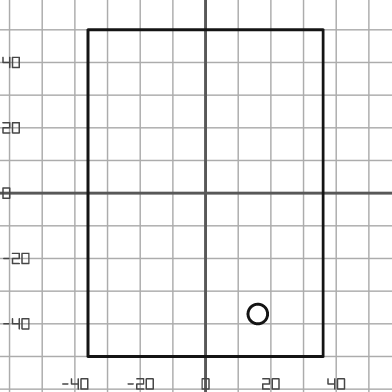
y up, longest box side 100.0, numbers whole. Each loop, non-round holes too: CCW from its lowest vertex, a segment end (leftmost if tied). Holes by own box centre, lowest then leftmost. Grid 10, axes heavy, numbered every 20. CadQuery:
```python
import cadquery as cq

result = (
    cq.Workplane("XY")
    .moveTo(-36.0, -50.0)
    .lineTo(36.0, -50.0)
    .lineTo(36.0, 50.0)
    .lineTo(-36.0, 50.0)
    .close()
    .moveTo(16.0, -37.0)
    .circle(3.0)
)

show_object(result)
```